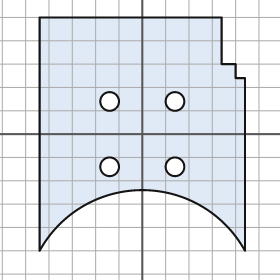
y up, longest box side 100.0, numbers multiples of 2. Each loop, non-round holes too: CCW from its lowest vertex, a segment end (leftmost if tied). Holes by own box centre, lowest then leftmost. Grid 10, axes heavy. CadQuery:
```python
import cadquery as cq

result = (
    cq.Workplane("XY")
    .moveTo(-44.0, -50.0)
    .threePointArc((0.0, -24.0), (44.0, -50.0))
    .lineTo(44.0, 24.0)
    .lineTo(40.0, 24.0)
    .lineTo(40.0, 30.0)
    .lineTo(34.0, 30.0)
    .lineTo(34.0, 50.0)
    .lineTo(-44.0, 50.0)
    .close()
    .moveTo(-14.0, -14.0)
    .circle(4.0)
    .moveTo(14.0, -14.0)
    .circle(4.0)
    .moveTo(-14.0, 14.0)
    .circle(4.0)
    .moveTo(14.0, 14.0)
    .circle(4.0)
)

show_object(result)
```